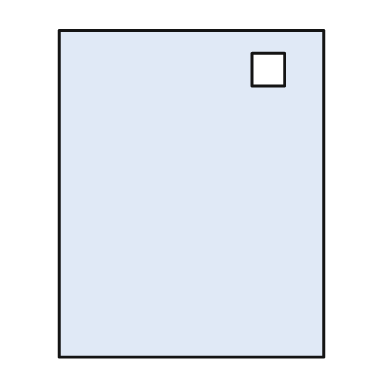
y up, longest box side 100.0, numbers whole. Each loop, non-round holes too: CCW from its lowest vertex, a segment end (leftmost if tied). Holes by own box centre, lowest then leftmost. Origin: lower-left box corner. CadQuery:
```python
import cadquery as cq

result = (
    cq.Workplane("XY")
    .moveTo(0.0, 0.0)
    .lineTo(81.0, 0.0)
    .lineTo(81.0, 100.0)
    .lineTo(0.0, 100.0)
    .close()
    .moveTo(59.0, 83.0)
    .lineTo(69.0, 83.0)
    .lineTo(69.0, 93.0)
    .lineTo(59.0, 93.0)
    .close()
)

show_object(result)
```